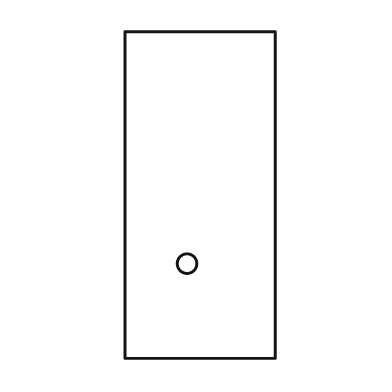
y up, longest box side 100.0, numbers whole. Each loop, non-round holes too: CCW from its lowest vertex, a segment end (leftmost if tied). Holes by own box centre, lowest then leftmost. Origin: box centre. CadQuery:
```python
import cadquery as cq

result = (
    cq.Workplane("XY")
    .moveTo(-23.0, -50.0)
    .lineTo(23.0, -50.0)
    .lineTo(23.0, 50.0)
    .lineTo(-23.0, 50.0)
    .close()
    .moveTo(-4.0, -21.0)
    .circle(3.0)
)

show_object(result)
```